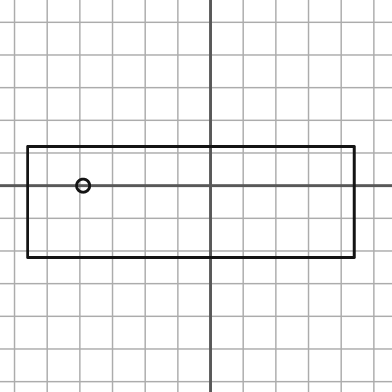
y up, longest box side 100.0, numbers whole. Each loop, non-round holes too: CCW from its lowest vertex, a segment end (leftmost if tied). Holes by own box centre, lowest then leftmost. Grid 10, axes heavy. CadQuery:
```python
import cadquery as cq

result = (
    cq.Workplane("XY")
    .moveTo(-56.0, -22.0)
    .lineTo(44.0, -22.0)
    .lineTo(44.0, 12.0)
    .lineTo(-56.0, 12.0)
    .close()
    .moveTo(-39.0, 0.0)
    .circle(2.0)
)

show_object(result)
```